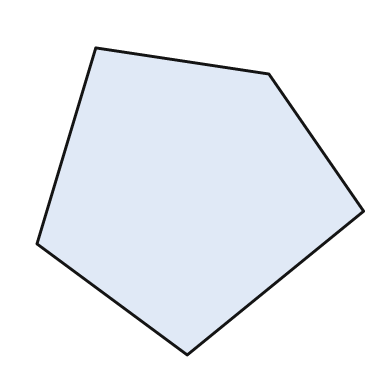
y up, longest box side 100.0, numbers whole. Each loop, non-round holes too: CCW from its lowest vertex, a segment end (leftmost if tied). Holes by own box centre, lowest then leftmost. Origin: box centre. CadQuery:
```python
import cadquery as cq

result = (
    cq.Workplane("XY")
    .moveTo(-4.0, -47.0)
    .lineTo(50.0, -3.0)
    .lineTo(21.0, 39.0)
    .lineTo(-32.0, 47.0)
    .lineTo(-50.0, -13.0)
    .close()
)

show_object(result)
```